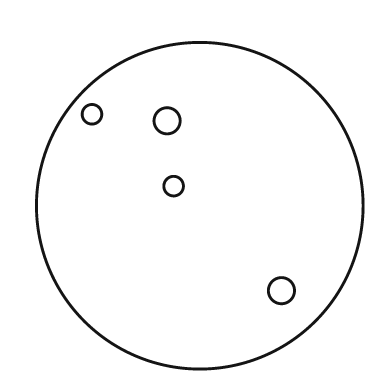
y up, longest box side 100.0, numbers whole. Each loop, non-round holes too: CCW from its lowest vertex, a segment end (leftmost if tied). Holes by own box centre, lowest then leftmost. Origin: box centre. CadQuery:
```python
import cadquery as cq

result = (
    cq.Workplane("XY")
    .moveTo(0.0, 0.0)
    .circle(50.0)
    .moveTo(25.0, -26.0)
    .circle(4.0)
    .moveTo(-8.0, 6.0)
    .circle(3.0)
    .moveTo(-10.0, 26.0)
    .circle(4.0)
    .moveTo(-33.0, 28.0)
    .circle(3.0)
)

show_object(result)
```